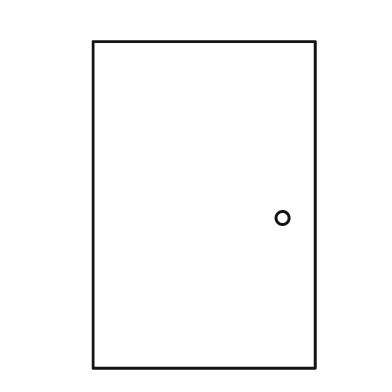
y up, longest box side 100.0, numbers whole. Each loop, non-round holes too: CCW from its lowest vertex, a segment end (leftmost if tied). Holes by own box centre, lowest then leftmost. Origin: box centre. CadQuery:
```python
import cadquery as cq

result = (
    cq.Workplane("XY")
    .moveTo(-34.0, -50.0)
    .lineTo(34.0, -50.0)
    .lineTo(34.0, 50.0)
    .lineTo(-34.0, 50.0)
    .close()
    .moveTo(24.0, -4.0)
    .circle(2.0)
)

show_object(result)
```